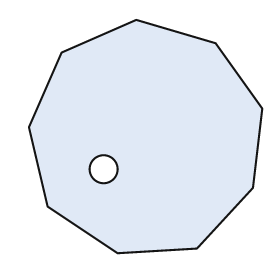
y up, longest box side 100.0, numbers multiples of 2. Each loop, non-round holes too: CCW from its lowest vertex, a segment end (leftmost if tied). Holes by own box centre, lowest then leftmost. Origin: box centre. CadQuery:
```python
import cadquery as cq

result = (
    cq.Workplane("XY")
    .moveTo(-12.0, -50.0)
    .lineTo(22.0, -48.0)
    .lineTo(46.0, -22.0)
    .lineTo(50.0, 12.0)
    .lineTo(30.0, 40.0)
    .lineTo(-4.0, 50.0)
    .lineTo(-36.0, 36.0)
    .lineTo(-50.0, 4.0)
    .lineTo(-42.0, -30.0)
    .close()
    .moveTo(-18.0, -14.0)
    .circle(6.0)
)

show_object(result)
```